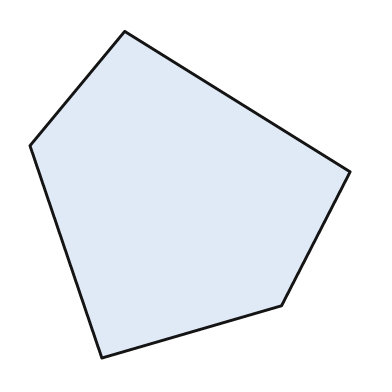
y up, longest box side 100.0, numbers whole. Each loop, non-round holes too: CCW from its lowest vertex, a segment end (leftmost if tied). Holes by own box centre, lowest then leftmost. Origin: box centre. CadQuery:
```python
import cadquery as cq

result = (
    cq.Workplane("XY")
    .moveTo(-27.0, -50.0)
    .lineTo(28.0, -34.0)
    .lineTo(49.0, 7.0)
    .lineTo(-20.0, 50.0)
    .lineTo(-49.0, 15.0)
    .close()
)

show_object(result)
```